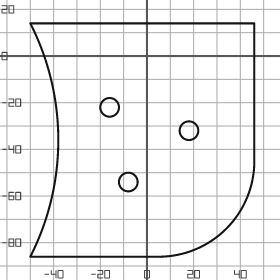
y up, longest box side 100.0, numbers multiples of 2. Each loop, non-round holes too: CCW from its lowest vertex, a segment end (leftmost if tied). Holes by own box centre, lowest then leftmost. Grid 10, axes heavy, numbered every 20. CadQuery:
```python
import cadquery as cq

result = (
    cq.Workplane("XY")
    .moveTo(-50.0, -86.0)
    .lineTo(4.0, -86.0)
    .threePointArc((34.0, -74.0), (46.0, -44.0))
    .lineTo(46.0, 14.0)
    .lineTo(-50.0, 14.0)
    .threePointArc((-38.0, -36.0), (-50.0, -86.0))
    .close()
    .moveTo(-8.0, -54.0)
    .circle(4.0)
    .moveTo(18.0, -32.0)
    .circle(4.0)
    .moveTo(-16.0, -22.0)
    .circle(4.0)
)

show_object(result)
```